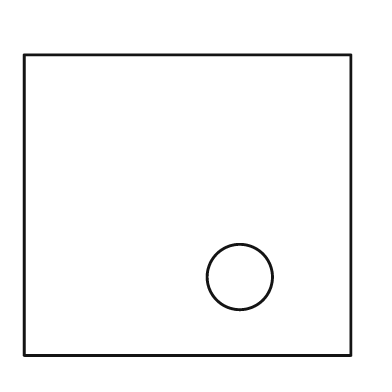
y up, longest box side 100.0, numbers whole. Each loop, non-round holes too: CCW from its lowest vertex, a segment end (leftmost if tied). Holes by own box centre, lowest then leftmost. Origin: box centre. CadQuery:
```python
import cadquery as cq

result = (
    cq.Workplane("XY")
    .moveTo(-50.0, -46.0)
    .lineTo(50.0, -46.0)
    .lineTo(50.0, 46.0)
    .lineTo(-50.0, 46.0)
    .close()
    .moveTo(16.0, -22.0)
    .circle(10.0)
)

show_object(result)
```